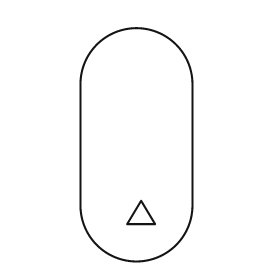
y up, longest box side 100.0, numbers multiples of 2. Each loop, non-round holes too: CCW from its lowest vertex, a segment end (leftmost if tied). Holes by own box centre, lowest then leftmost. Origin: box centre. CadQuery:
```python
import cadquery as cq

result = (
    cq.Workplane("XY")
    .moveTo(-24.0, -26.0)
    .threePointArc((0.0, -50.0), (24.0, -26.0))
    .lineTo(24.0, 26.0)
    .threePointArc((0.0, 50.0), (-24.0, 26.0))
    .close()
    .moveTo(-4.0, -34.0)
    .lineTo(8.0, -34.0)
    .lineTo(2.0, -24.0)
    .close()
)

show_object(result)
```